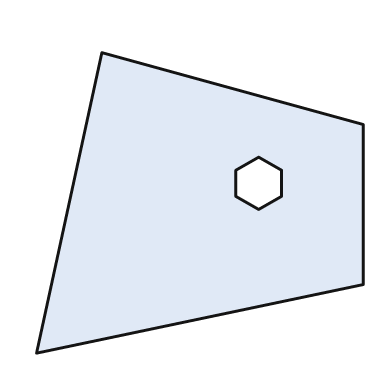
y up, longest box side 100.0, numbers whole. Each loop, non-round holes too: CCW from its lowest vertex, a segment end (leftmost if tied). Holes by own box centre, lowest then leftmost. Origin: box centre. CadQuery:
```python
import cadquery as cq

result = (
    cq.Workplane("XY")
    .moveTo(-50.0, -46.0)
    .lineTo(50.0, -25.0)
    .lineTo(50.0, 24.0)
    .lineTo(-30.0, 46.0)
    .close()
    .moveTo(18.0, -2.0)
    .lineTo(25.0, 2.0)
    .lineTo(25.0, 10.0)
    .lineTo(18.0, 14.0)
    .lineTo(11.0, 10.0)
    .lineTo(11.0, 2.0)
    .close()
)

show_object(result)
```